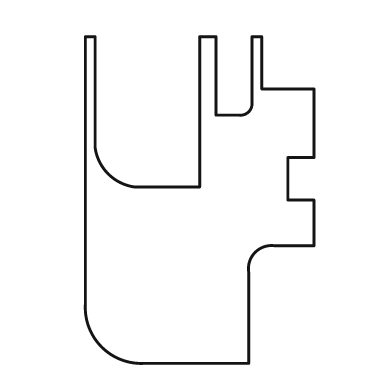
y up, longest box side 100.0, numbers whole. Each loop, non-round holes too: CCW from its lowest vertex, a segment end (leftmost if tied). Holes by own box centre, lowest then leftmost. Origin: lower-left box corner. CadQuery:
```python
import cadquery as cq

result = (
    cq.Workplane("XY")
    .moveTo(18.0, 0.0)
    .lineTo(50.0, 0.0)
    .lineTo(50.0, 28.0)
    .threePointArc((52.0, 34.0), (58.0, 36.0))
    .lineTo(70.0, 36.0)
    .lineTo(70.0, 50.0)
    .lineTo(62.0, 50.0)
    .lineTo(62.0, 63.0)
    .lineTo(70.0, 63.0)
    .lineTo(70.0, 84.0)
    .lineTo(54.0, 84.0)
    .lineTo(54.0, 100.0)
    .lineTo(51.0, 100.0)
    .lineTo(51.0, 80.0)
    .threePointArc((50.0, 77.0), (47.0, 76.0))
    .lineTo(40.0, 76.0)
    .lineTo(40.0, 100.0)
    .lineTo(35.0, 100.0)
    .lineTo(35.0, 54.0)
    .lineTo(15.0, 54.0)
    .threePointArc((7.0, 58.0), (3.0, 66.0))
    .lineTo(3.0, 100.0)
    .lineTo(0.0, 100.0)
    .lineTo(0.0, 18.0)
    .threePointArc((5.0, 5.0), (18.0, 0.0))
    .close()
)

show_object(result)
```